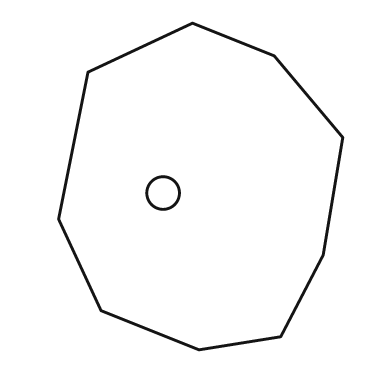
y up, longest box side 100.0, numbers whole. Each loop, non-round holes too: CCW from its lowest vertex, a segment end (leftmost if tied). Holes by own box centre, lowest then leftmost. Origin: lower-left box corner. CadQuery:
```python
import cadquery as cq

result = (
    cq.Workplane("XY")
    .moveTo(43.0, 0.0)
    .lineTo(68.0, 4.0)
    .lineTo(81.0, 29.0)
    .lineTo(87.0, 65.0)
    .lineTo(66.0, 90.0)
    .lineTo(41.0, 100.0)
    .lineTo(9.0, 85.0)
    .lineTo(0.0, 40.0)
    .lineTo(13.0, 12.0)
    .close()
    .moveTo(32.0, 48.0)
    .circle(5.0)
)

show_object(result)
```